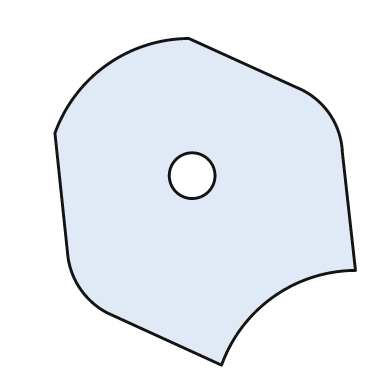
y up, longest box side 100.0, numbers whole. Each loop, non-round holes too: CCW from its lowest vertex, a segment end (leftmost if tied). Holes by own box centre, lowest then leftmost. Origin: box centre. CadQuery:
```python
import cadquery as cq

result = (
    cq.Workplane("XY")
    .moveTo(5.0, -50.0)
    .threePointArc((21.0, -29.0), (46.0, -21.0))
    .lineTo(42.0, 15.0)
    .threePointArc((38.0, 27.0), (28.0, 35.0))
    .lineTo(-5.0, 50.0)
    .threePointArc((-30.0, 42.0), (-46.0, 21.0))
    .lineTo(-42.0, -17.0)
    .threePointArc((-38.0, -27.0), (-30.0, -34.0))
    .close()
    .moveTo(-4.0, 8.0)
    .circle(7.0)
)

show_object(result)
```